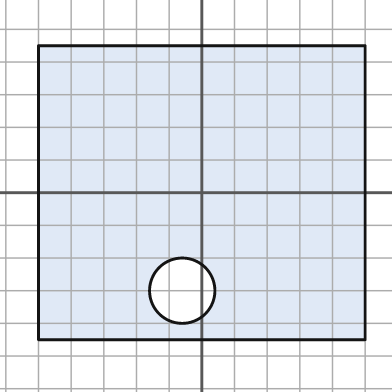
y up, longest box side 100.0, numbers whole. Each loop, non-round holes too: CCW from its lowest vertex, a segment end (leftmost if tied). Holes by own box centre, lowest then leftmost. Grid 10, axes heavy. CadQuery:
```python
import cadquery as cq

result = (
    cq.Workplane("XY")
    .moveTo(-50.0, -45.0)
    .lineTo(50.0, -45.0)
    .lineTo(50.0, 45.0)
    .lineTo(-50.0, 45.0)
    .close()
    .moveTo(-6.0, -30.0)
    .circle(10.0)
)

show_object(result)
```